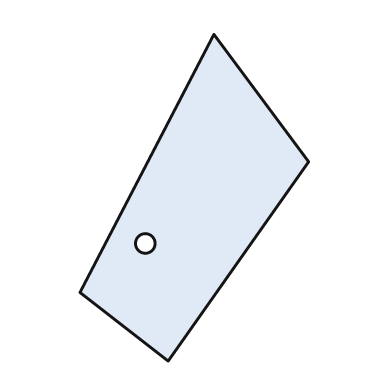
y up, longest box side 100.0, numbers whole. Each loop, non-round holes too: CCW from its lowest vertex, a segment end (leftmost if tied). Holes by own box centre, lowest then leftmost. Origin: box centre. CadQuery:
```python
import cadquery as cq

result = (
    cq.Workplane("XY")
    .moveTo(-8.0, -50.0)
    .lineTo(35.0, 11.0)
    .lineTo(6.0, 50.0)
    .lineTo(-35.0, -29.0)
    .close()
    .moveTo(-15.0, -14.0)
    .circle(3.0)
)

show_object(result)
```